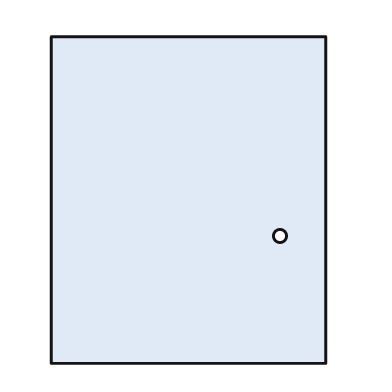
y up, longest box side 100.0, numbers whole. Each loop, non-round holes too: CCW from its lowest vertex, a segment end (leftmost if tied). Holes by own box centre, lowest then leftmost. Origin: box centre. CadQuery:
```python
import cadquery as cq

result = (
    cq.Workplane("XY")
    .moveTo(-42.0, -50.0)
    .lineTo(42.0, -50.0)
    .lineTo(42.0, 50.0)
    .lineTo(-42.0, 50.0)
    .close()
    .moveTo(28.0, -11.0)
    .circle(2.0)
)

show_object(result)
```